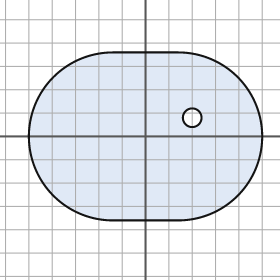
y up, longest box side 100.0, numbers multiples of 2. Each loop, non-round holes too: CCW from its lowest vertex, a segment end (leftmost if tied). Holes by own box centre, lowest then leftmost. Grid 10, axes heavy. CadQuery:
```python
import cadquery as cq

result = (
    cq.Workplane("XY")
    .moveTo(-14.0, -36.0)
    .lineTo(14.0, -36.0)
    .threePointArc((50.0, 0.0), (14.0, 36.0))
    .lineTo(-14.0, 36.0)
    .threePointArc((-50.0, 0.0), (-14.0, -36.0))
    .close()
    .moveTo(20.0, 8.0)
    .circle(4.0)
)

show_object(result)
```